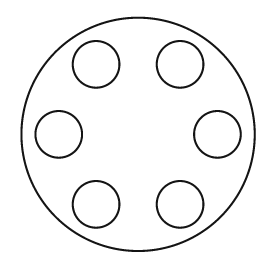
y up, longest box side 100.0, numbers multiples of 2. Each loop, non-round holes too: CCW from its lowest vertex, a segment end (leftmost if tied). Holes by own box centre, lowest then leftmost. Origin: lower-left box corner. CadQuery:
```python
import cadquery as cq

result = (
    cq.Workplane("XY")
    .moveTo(50.0, 50.0)
    .circle(50.0)
    .moveTo(32.0, 20.0)
    .circle(10.0)
    .moveTo(68.0, 20.0)
    .circle(10.0)
    .moveTo(16.0, 50.0)
    .circle(10.0)
    .moveTo(84.0, 50.0)
    .circle(10.0)
    .moveTo(32.0, 80.0)
    .circle(10.0)
    .moveTo(68.0, 80.0)
    .circle(10.0)
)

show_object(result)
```